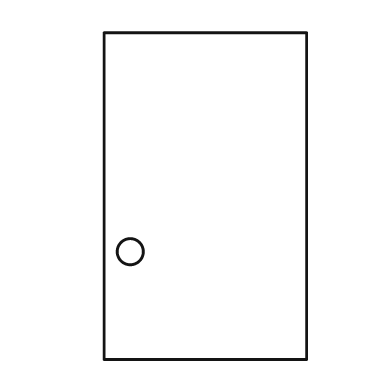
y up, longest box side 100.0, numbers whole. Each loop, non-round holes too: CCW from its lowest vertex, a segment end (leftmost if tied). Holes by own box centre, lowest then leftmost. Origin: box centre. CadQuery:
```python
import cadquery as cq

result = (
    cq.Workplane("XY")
    .moveTo(-31.0, -50.0)
    .lineTo(31.0, -50.0)
    .lineTo(31.0, 50.0)
    .lineTo(-31.0, 50.0)
    .close()
    .moveTo(-23.0, -17.0)
    .circle(4.0)
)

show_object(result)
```